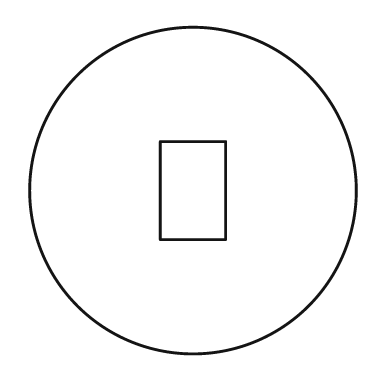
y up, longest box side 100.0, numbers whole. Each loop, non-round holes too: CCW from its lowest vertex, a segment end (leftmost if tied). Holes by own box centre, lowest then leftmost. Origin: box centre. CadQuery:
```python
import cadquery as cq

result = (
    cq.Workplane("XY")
    .moveTo(0.0, 0.0)
    .circle(50.0)
    .moveTo(-10.0, -15.0)
    .lineTo(10.0, -15.0)
    .lineTo(10.0, 15.0)
    .lineTo(-10.0, 15.0)
    .close()
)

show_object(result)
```